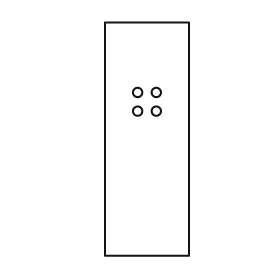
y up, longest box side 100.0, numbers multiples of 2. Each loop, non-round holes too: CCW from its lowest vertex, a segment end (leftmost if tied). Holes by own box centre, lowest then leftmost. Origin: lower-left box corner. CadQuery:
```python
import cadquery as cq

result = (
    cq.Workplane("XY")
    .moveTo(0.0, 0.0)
    .lineTo(36.0, 0.0)
    .lineTo(36.0, 100.0)
    .lineTo(0.0, 100.0)
    .close()
    .moveTo(14.0, 62.0)
    .circle(2.0)
    .moveTo(22.0, 62.0)
    .circle(2.0)
    .moveTo(14.0, 70.0)
    .circle(2.0)
    .moveTo(22.0, 70.0)
    .circle(2.0)
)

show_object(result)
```